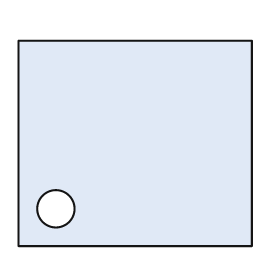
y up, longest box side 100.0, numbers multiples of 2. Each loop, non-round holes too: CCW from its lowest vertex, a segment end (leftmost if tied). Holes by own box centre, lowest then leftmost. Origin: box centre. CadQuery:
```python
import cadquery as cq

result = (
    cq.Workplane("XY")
    .moveTo(-50.0, -44.0)
    .lineTo(50.0, -44.0)
    .lineTo(50.0, 44.0)
    .lineTo(-50.0, 44.0)
    .close()
    .moveTo(-34.0, -28.0)
    .circle(8.0)
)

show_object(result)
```